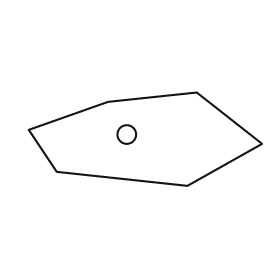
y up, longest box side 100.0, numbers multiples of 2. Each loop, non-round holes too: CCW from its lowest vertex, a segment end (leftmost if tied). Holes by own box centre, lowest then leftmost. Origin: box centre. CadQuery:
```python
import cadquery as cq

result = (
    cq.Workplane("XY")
    .moveTo(18.0, -20.0)
    .lineTo(50.0, -2.0)
    .lineTo(22.0, 20.0)
    .lineTo(-16.0, 16.0)
    .lineTo(-50.0, 4.0)
    .lineTo(-38.0, -14.0)
    .close()
    .moveTo(-8.0, 2.0)
    .circle(4.0)
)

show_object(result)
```